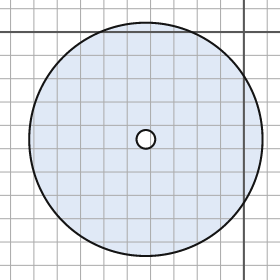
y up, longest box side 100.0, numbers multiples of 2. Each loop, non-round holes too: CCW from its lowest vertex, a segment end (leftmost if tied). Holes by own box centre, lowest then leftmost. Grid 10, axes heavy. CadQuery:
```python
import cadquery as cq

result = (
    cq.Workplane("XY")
    .moveTo(-42.0, -46.0)
    .circle(50.0)
    .moveTo(-42.0, -46.0)
    .circle(4.0)
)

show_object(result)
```